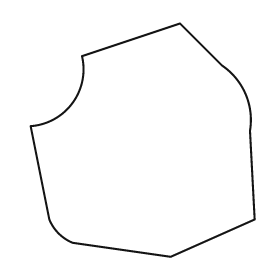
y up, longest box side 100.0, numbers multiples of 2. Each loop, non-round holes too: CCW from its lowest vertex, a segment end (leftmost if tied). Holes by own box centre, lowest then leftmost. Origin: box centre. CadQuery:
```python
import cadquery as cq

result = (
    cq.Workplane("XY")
    .moveTo(12.0, -50.0)
    .lineTo(48.0, -34.0)
    .lineTo(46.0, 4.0)
    .threePointArc((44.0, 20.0), (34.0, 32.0))
    .lineTo(16.0, 50.0)
    .lineTo(-26.0, 36.0)
    .threePointArc((-30.0, 16.0), (-48.0, 6.0))
    .lineTo(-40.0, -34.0)
    .threePointArc((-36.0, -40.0), (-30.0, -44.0))
    .close()
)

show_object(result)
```